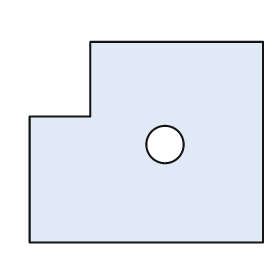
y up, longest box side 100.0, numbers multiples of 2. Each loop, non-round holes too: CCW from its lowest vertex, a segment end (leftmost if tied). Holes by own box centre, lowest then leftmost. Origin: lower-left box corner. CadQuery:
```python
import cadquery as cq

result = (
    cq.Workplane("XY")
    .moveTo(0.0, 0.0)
    .lineTo(100.0, 0.0)
    .lineTo(100.0, 86.0)
    .lineTo(26.0, 86.0)
    .lineTo(26.0, 54.0)
    .lineTo(0.0, 54.0)
    .close()
    .moveTo(58.0, 42.0)
    .circle(8.0)
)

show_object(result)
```